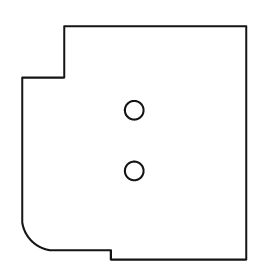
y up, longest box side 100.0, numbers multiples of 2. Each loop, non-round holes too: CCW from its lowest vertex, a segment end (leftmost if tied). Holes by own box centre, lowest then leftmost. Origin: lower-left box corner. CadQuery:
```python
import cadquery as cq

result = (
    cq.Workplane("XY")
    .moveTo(38.0, 0.0)
    .lineTo(96.0, 0.0)
    .lineTo(96.0, 100.0)
    .lineTo(18.0, 100.0)
    .lineTo(18.0, 78.0)
    .lineTo(0.0, 78.0)
    .lineTo(0.0, 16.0)
    .threePointArc((4.0, 8.0), (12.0, 4.0))
    .lineTo(38.0, 4.0)
    .close()
    .moveTo(48.0, 38.0)
    .circle(4.0)
    .moveTo(48.0, 64.0)
    .circle(4.0)
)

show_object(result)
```